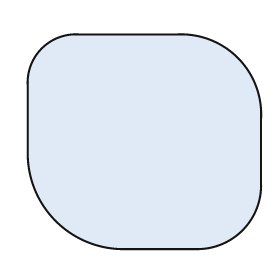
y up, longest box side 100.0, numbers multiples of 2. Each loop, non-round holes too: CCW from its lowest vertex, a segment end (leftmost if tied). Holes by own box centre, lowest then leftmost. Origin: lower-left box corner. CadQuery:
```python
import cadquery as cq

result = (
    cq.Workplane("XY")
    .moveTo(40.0, 0.0)
    .lineTo(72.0, 0.0)
    .threePointArc((92.0, 8.0), (100.0, 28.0))
    .lineTo(100.0, 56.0)
    .threePointArc((90.0, 82.0), (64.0, 92.0))
    .lineTo(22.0, 92.0)
    .threePointArc((6.0, 86.0), (0.0, 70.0))
    .lineTo(0.0, 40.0)
    .threePointArc((12.0, 12.0), (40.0, 0.0))
    .close()
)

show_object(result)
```